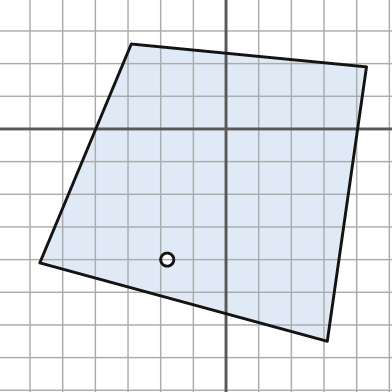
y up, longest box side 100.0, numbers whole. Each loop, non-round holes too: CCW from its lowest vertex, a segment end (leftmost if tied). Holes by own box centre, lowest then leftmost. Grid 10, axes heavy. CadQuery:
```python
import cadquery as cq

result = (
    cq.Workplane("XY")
    .moveTo(31.0, -65.0)
    .lineTo(43.0, 19.0)
    .lineTo(-29.0, 26.0)
    .lineTo(-57.0, -41.0)
    .close()
    .moveTo(-18.0, -40.0)
    .circle(2.0)
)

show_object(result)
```